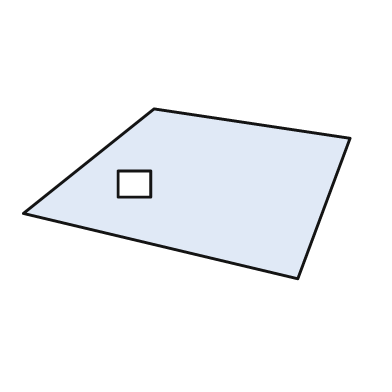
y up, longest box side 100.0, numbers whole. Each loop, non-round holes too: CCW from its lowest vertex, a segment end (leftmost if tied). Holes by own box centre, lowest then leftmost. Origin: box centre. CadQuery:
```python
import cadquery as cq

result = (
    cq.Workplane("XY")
    .moveTo(34.0, -26.0)
    .lineTo(50.0, 17.0)
    .lineTo(-10.0, 26.0)
    .lineTo(-50.0, -6.0)
    .close()
    .moveTo(-21.0, -1.0)
    .lineTo(-11.0, -1.0)
    .lineTo(-11.0, 7.0)
    .lineTo(-21.0, 7.0)
    .close()
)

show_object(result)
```